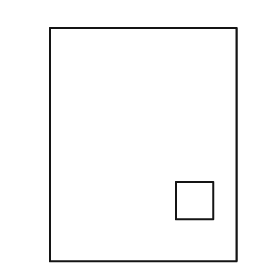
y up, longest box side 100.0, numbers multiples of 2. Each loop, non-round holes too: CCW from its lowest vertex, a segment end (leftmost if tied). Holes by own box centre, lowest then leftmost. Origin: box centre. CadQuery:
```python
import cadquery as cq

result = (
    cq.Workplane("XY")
    .moveTo(-40.0, -50.0)
    .lineTo(40.0, -50.0)
    .lineTo(40.0, 50.0)
    .lineTo(-40.0, 50.0)
    .close()
    .moveTo(14.0, -32.0)
    .lineTo(30.0, -32.0)
    .lineTo(30.0, -16.0)
    .lineTo(14.0, -16.0)
    .close()
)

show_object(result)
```